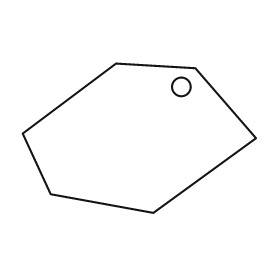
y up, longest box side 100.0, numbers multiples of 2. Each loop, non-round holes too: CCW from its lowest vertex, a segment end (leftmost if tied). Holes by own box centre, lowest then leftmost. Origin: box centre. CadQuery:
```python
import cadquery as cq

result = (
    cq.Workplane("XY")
    .moveTo(6.0, -32.0)
    .lineTo(50.0, 0.0)
    .lineTo(24.0, 30.0)
    .lineTo(-10.0, 32.0)
    .lineTo(-50.0, 2.0)
    .lineTo(-38.0, -24.0)
    .close()
    .moveTo(18.0, 22.0)
    .circle(4.0)
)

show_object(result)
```